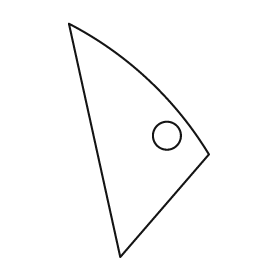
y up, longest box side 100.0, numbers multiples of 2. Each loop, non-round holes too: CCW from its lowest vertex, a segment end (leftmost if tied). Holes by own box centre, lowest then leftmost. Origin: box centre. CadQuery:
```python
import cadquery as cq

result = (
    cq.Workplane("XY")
    .moveTo(-8.0, -50.0)
    .lineTo(30.0, -6.0)
    .threePointArc((4.0, 26.0), (-30.0, 50.0))
    .close()
    .moveTo(12.0, 2.0)
    .circle(6.0)
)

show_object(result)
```